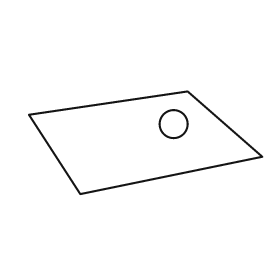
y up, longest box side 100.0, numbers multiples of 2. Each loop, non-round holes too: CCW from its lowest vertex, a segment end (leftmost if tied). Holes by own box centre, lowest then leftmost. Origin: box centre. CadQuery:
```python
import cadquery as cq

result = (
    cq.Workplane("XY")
    .moveTo(-28.0, -22.0)
    .lineTo(50.0, -6.0)
    .lineTo(18.0, 22.0)
    .lineTo(-50.0, 12.0)
    .close()
    .moveTo(12.0, 8.0)
    .circle(6.0)
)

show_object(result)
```